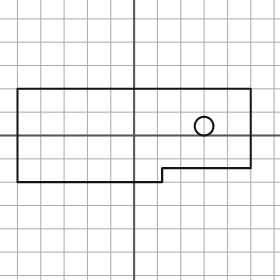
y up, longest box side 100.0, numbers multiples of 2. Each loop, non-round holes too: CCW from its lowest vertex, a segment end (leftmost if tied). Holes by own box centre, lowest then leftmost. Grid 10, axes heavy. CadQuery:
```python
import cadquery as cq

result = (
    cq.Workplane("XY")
    .moveTo(-50.0, -20.0)
    .lineTo(12.0, -20.0)
    .lineTo(12.0, -14.0)
    .lineTo(50.0, -14.0)
    .lineTo(50.0, 20.0)
    .lineTo(-50.0, 20.0)
    .close()
    .moveTo(30.0, 4.0)
    .circle(4.0)
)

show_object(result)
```